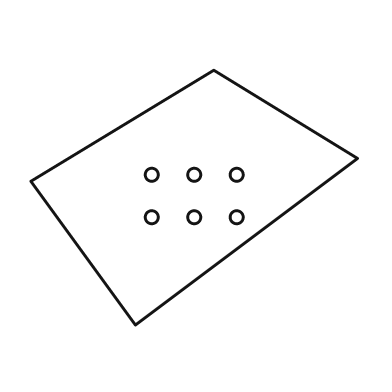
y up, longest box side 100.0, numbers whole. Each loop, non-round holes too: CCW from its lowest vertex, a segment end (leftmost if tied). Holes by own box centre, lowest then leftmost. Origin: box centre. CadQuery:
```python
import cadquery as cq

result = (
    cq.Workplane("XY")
    .moveTo(-18.0, -39.0)
    .lineTo(50.0, 12.0)
    .lineTo(6.0, 39.0)
    .lineTo(-50.0, 5.0)
    .close()
    .moveTo(-13.0, -6.0)
    .circle(2.0)
    .moveTo(0.0, -6.0)
    .circle(2.0)
    .moveTo(13.0, -6.0)
    .circle(2.0)
    .moveTo(-13.0, 7.0)
    .circle(2.0)
    .moveTo(0.0, 7.0)
    .circle(2.0)
    .moveTo(13.0, 7.0)
    .circle(2.0)
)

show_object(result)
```